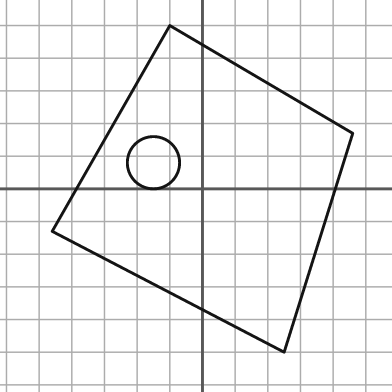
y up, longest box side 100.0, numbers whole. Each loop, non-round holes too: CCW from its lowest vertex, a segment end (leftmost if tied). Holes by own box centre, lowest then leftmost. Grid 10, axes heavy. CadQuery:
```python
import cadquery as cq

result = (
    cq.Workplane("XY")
    .moveTo(25.0, -50.0)
    .lineTo(46.0, 17.0)
    .lineTo(-10.0, 50.0)
    .lineTo(-46.0, -13.0)
    .close()
    .moveTo(-15.0, 8.0)
    .circle(8.0)
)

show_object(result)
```